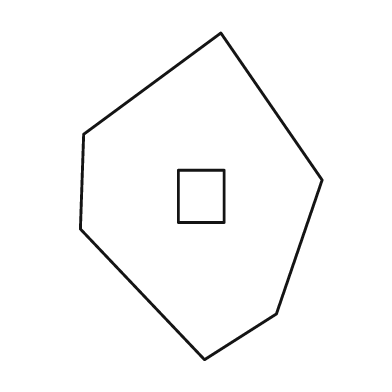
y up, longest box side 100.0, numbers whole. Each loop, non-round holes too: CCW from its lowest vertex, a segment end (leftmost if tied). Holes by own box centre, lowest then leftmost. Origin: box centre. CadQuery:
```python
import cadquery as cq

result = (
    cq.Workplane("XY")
    .moveTo(1.0, -50.0)
    .lineTo(23.0, -36.0)
    .lineTo(37.0, 5.0)
    .lineTo(6.0, 50.0)
    .lineTo(-36.0, 19.0)
    .lineTo(-37.0, -10.0)
    .close()
    .moveTo(-7.0, -8.0)
    .lineTo(7.0, -8.0)
    .lineTo(7.0, 8.0)
    .lineTo(-7.0, 8.0)
    .close()
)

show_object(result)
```